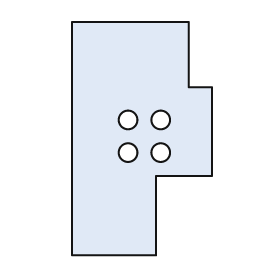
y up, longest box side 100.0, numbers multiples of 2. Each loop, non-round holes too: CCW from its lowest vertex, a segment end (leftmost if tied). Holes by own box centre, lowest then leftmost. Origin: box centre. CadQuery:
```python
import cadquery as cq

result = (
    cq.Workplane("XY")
    .moveTo(-30.0, -50.0)
    .lineTo(6.0, -50.0)
    .lineTo(6.0, -16.0)
    .lineTo(30.0, -16.0)
    .lineTo(30.0, 22.0)
    .lineTo(20.0, 22.0)
    .lineTo(20.0, 50.0)
    .lineTo(-30.0, 50.0)
    .close()
    .moveTo(-6.0, -6.0)
    .circle(4.0)
    .moveTo(8.0, -6.0)
    .circle(4.0)
    .moveTo(-6.0, 8.0)
    .circle(4.0)
    .moveTo(8.0, 8.0)
    .circle(4.0)
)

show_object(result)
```